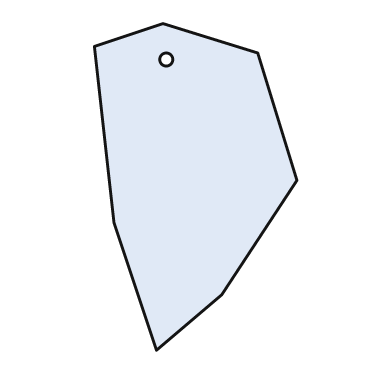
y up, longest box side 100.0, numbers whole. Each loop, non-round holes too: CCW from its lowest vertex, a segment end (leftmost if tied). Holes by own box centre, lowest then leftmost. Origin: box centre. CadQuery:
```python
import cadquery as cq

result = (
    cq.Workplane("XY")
    .moveTo(-12.0, -50.0)
    .lineTo(8.0, -33.0)
    .lineTo(31.0, 2.0)
    .lineTo(19.0, 41.0)
    .lineTo(-10.0, 50.0)
    .lineTo(-31.0, 43.0)
    .lineTo(-25.0, -11.0)
    .close()
    .moveTo(-9.0, 39.0)
    .circle(2.0)
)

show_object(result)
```